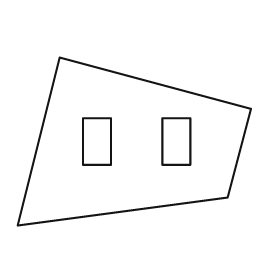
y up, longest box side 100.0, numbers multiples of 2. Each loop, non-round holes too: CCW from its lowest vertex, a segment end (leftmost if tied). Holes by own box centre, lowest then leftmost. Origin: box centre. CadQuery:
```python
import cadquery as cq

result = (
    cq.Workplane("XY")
    .moveTo(-50.0, -36.0)
    .lineTo(40.0, -24.0)
    .lineTo(50.0, 14.0)
    .lineTo(-32.0, 36.0)
    .close()
    .moveTo(-22.0, -10.0)
    .lineTo(-10.0, -10.0)
    .lineTo(-10.0, 10.0)
    .lineTo(-22.0, 10.0)
    .close()
    .moveTo(12.0, -10.0)
    .lineTo(24.0, -10.0)
    .lineTo(24.0, 10.0)
    .lineTo(12.0, 10.0)
    .close()
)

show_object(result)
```